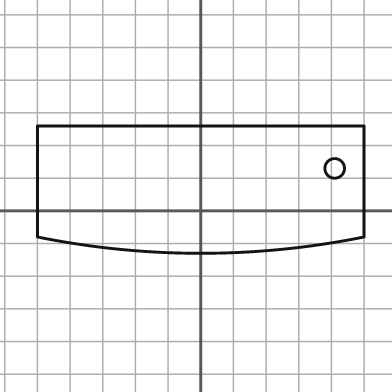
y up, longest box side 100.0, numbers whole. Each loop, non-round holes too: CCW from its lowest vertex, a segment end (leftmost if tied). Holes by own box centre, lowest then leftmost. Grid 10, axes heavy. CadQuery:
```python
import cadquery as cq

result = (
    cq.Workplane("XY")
    .moveTo(-50.0, -8.0)
    .threePointArc((0.0, -13.0), (50.0, -8.0))
    .lineTo(50.0, 26.0)
    .lineTo(-50.0, 26.0)
    .close()
    .moveTo(41.0, 13.0)
    .circle(3.0)
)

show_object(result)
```